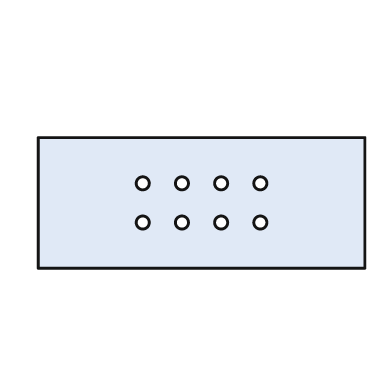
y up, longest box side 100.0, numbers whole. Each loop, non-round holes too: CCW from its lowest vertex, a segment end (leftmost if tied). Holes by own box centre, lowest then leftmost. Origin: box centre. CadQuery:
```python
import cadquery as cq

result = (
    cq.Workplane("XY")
    .moveTo(-50.0, -20.0)
    .lineTo(50.0, -20.0)
    .lineTo(50.0, 20.0)
    .lineTo(-50.0, 20.0)
    .close()
    .moveTo(-18.0, -6.0)
    .circle(2.0)
    .moveTo(-6.0, -6.0)
    .circle(2.0)
    .moveTo(6.0, -6.0)
    .circle(2.0)
    .moveTo(18.0, -6.0)
    .circle(2.0)
    .moveTo(-18.0, 6.0)
    .circle(2.0)
    .moveTo(-6.0, 6.0)
    .circle(2.0)
    .moveTo(6.0, 6.0)
    .circle(2.0)
    .moveTo(18.0, 6.0)
    .circle(2.0)
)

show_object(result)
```